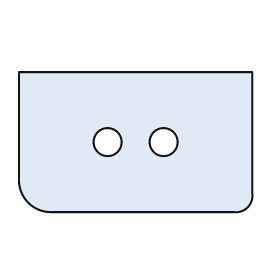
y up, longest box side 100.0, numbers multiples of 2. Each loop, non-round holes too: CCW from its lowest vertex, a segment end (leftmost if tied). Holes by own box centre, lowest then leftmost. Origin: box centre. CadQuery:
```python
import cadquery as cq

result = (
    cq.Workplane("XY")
    .moveTo(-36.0, -30.0)
    .lineTo(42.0, -30.0)
    .threePointArc((48.0, -28.0), (50.0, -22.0))
    .lineTo(50.0, 30.0)
    .lineTo(-50.0, 30.0)
    .lineTo(-50.0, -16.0)
    .threePointArc((-46.0, -26.0), (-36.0, -30.0))
    .close()
    .moveTo(-12.0, 0.0)
    .circle(6.0)
    .moveTo(12.0, 0.0)
    .circle(6.0)
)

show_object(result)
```